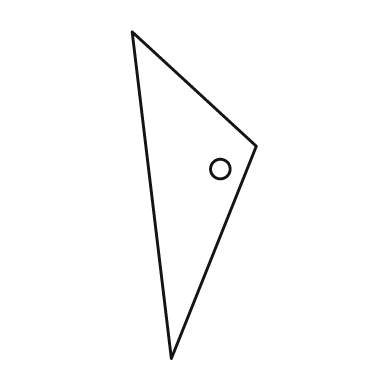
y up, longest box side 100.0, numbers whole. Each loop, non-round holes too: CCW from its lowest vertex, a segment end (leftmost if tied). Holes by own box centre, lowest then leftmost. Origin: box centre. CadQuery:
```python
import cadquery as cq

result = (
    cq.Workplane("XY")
    .moveTo(-7.0, -50.0)
    .lineTo(19.0, 15.0)
    .lineTo(-19.0, 50.0)
    .close()
    .moveTo(8.0, 8.0)
    .circle(3.0)
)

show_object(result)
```